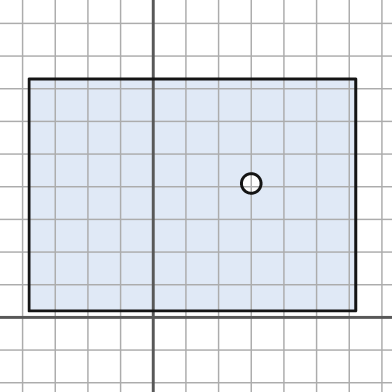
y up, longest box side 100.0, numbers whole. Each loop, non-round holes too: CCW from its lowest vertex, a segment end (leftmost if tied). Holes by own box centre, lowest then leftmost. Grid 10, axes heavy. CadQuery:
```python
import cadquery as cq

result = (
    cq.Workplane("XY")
    .moveTo(-38.0, 2.0)
    .lineTo(62.0, 2.0)
    .lineTo(62.0, 73.0)
    .lineTo(-38.0, 73.0)
    .close()
    .moveTo(30.0, 41.0)
    .circle(3.0)
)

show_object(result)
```